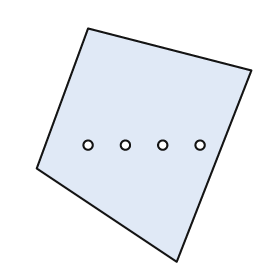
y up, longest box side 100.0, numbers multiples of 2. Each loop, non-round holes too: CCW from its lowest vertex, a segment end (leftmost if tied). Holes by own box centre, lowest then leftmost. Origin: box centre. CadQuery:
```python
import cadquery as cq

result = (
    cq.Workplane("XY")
    .moveTo(14.0, -50.0)
    .lineTo(46.0, 32.0)
    .lineTo(-24.0, 50.0)
    .lineTo(-46.0, -10.0)
    .close()
    .moveTo(-24.0, 0.0)
    .circle(2.0)
    .moveTo(-8.0, 0.0)
    .circle(2.0)
    .moveTo(8.0, 0.0)
    .circle(2.0)
    .moveTo(24.0, 0.0)
    .circle(2.0)
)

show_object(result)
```